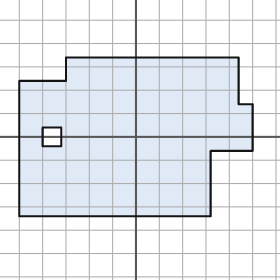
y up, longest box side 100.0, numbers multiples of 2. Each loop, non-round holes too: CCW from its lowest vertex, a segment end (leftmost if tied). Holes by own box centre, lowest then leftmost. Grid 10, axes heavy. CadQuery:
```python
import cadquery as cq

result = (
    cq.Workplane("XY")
    .moveTo(-50.0, -34.0)
    .lineTo(32.0, -34.0)
    .lineTo(32.0, -6.0)
    .lineTo(50.0, -6.0)
    .lineTo(50.0, 14.0)
    .lineTo(44.0, 14.0)
    .lineTo(44.0, 34.0)
    .lineTo(-30.0, 34.0)
    .lineTo(-30.0, 24.0)
    .lineTo(-50.0, 24.0)
    .close()
    .moveTo(-40.0, -4.0)
    .lineTo(-32.0, -4.0)
    .lineTo(-32.0, 4.0)
    .lineTo(-40.0, 4.0)
    .close()
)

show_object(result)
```